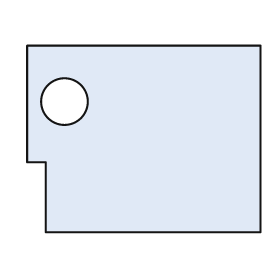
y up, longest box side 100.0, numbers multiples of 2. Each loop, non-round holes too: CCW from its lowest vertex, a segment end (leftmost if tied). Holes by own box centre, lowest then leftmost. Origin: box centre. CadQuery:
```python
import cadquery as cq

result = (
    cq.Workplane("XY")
    .moveTo(-42.0, -40.0)
    .lineTo(50.0, -40.0)
    .lineTo(50.0, 40.0)
    .lineTo(-50.0, 40.0)
    .lineTo(-50.0, -10.0)
    .lineTo(-42.0, -10.0)
    .close()
    .moveTo(-34.0, 16.0)
    .circle(10.0)
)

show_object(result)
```